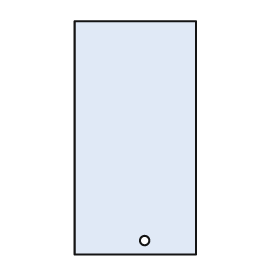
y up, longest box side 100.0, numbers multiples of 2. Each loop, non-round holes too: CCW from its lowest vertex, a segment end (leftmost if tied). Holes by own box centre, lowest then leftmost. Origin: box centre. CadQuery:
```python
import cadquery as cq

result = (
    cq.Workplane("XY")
    .moveTo(-26.0, -50.0)
    .lineTo(26.0, -50.0)
    .lineTo(26.0, 50.0)
    .lineTo(-26.0, 50.0)
    .close()
    .moveTo(4.0, -44.0)
    .circle(2.0)
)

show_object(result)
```